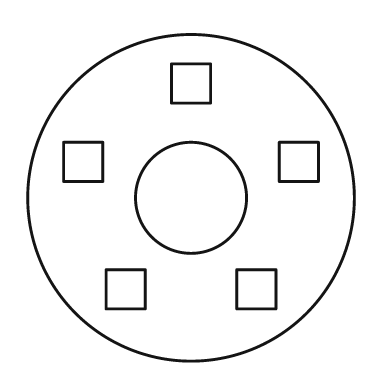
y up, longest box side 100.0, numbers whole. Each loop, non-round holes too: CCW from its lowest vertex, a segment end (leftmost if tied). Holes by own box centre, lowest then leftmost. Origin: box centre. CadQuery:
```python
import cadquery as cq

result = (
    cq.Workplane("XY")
    .moveTo(0.0, 0.0)
    .circle(50.0)
    .moveTo(-26.0, -34.0)
    .lineTo(-14.0, -34.0)
    .lineTo(-14.0, -22.0)
    .lineTo(-26.0, -22.0)
    .close()
    .moveTo(14.0, -34.0)
    .lineTo(26.0, -34.0)
    .lineTo(26.0, -22.0)
    .lineTo(14.0, -22.0)
    .close()
    .moveTo(0.0, 0.0)
    .circle(17.0)
    .moveTo(-39.0, 5.0)
    .lineTo(-27.0, 5.0)
    .lineTo(-27.0, 17.0)
    .lineTo(-39.0, 17.0)
    .close()
    .moveTo(27.0, 5.0)
    .lineTo(39.0, 5.0)
    .lineTo(39.0, 17.0)
    .lineTo(27.0, 17.0)
    .close()
    .moveTo(-6.0, 29.0)
    .lineTo(6.0, 29.0)
    .lineTo(6.0, 41.0)
    .lineTo(-6.0, 41.0)
    .close()
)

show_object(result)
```